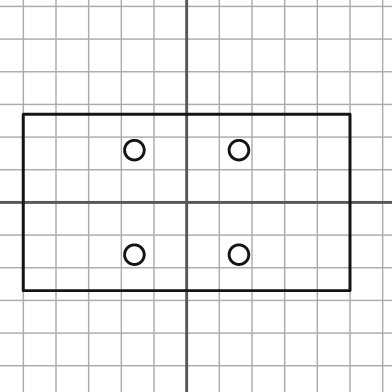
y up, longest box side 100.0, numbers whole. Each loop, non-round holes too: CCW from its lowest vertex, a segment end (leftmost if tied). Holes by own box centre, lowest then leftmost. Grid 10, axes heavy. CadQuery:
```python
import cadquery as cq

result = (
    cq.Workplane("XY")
    .moveTo(-50.0, -27.0)
    .lineTo(50.0, -27.0)
    .lineTo(50.0, 27.0)
    .lineTo(-50.0, 27.0)
    .close()
    .moveTo(-16.0, -16.0)
    .circle(3.0)
    .moveTo(16.0, -16.0)
    .circle(3.0)
    .moveTo(-16.0, 16.0)
    .circle(3.0)
    .moveTo(16.0, 16.0)
    .circle(3.0)
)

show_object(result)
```